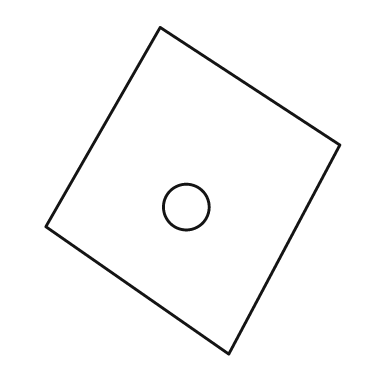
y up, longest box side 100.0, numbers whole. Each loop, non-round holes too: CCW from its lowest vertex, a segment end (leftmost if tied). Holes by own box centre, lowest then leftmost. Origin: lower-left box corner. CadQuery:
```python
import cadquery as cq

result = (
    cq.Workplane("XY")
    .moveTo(56.0, 0.0)
    .lineTo(90.0, 64.0)
    .lineTo(35.0, 100.0)
    .lineTo(0.0, 39.0)
    .close()
    .moveTo(43.0, 45.0)
    .circle(7.0)
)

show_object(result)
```